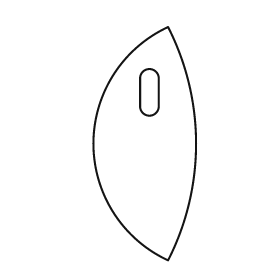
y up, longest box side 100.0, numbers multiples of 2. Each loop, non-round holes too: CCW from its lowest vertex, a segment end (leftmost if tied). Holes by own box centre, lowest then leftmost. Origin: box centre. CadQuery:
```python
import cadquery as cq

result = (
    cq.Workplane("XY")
    .moveTo(10.0, -50.0)
    .threePointArc((22.0, 0.0), (10.0, 50.0))
    .threePointArc((-22.0, 0.0), (10.0, -50.0))
    .close()
    .moveTo(-2.0, 16.0)
    .threePointArc((2.0, 12.0), (6.0, 16.0))
    .lineTo(6.0, 28.0)
    .threePointArc((2.0, 32.0), (-2.0, 28.0))
    .close()
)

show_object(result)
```